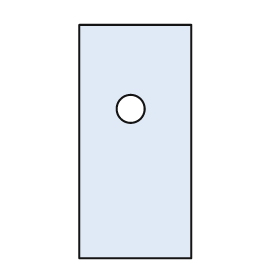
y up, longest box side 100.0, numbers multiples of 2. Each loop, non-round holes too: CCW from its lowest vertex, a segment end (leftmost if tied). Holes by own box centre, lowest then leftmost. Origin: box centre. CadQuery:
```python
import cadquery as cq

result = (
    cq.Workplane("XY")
    .moveTo(-24.0, -50.0)
    .lineTo(24.0, -50.0)
    .lineTo(24.0, 50.0)
    .lineTo(-24.0, 50.0)
    .close()
    .moveTo(-2.0, 14.0)
    .circle(6.0)
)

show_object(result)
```